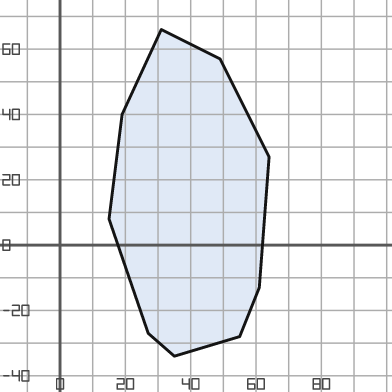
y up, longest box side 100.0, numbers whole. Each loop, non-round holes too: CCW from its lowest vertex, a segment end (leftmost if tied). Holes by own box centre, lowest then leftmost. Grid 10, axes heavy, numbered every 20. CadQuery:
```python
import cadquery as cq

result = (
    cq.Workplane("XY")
    .moveTo(35.0, -34.0)
    .lineTo(55.0, -28.0)
    .lineTo(61.0, -13.0)
    .lineTo(64.0, 27.0)
    .lineTo(49.0, 57.0)
    .lineTo(31.0, 66.0)
    .lineTo(19.0, 40.0)
    .lineTo(15.0, 8.0)
    .lineTo(27.0, -27.0)
    .close()
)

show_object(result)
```